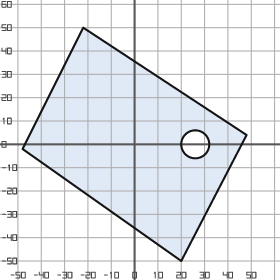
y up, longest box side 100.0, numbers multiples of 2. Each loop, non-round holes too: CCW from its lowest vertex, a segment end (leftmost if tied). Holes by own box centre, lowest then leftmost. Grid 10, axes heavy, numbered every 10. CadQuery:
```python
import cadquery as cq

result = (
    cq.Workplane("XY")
    .moveTo(20.0, -50.0)
    .lineTo(48.0, 4.0)
    .lineTo(-22.0, 50.0)
    .lineTo(-48.0, -2.0)
    .close()
    .moveTo(26.0, 0.0)
    .circle(6.0)
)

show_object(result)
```